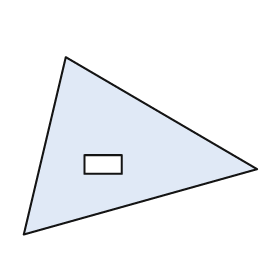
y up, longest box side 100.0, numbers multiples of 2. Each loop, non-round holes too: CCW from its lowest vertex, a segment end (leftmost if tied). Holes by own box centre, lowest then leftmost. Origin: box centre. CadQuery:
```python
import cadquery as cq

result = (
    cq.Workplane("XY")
    .moveTo(-50.0, -38.0)
    .lineTo(50.0, -10.0)
    .lineTo(-32.0, 38.0)
    .close()
    .moveTo(-24.0, -12.0)
    .lineTo(-8.0, -12.0)
    .lineTo(-8.0, -4.0)
    .lineTo(-24.0, -4.0)
    .close()
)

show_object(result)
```